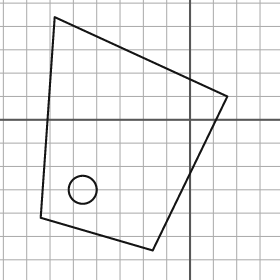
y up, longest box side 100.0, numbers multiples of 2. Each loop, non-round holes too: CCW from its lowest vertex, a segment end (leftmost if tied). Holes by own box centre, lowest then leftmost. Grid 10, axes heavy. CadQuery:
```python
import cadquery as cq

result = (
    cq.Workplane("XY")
    .moveTo(-16.0, -56.0)
    .lineTo(16.0, 10.0)
    .lineTo(-58.0, 44.0)
    .lineTo(-64.0, -42.0)
    .close()
    .moveTo(-46.0, -30.0)
    .circle(6.0)
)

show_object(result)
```